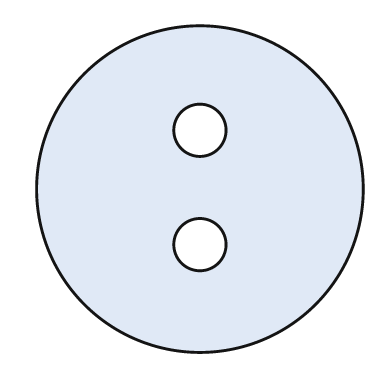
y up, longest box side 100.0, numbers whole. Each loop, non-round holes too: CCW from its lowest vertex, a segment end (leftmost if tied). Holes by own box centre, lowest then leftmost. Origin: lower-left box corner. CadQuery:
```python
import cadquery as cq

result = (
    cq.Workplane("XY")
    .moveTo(50.0, 50.0)
    .circle(50.0)
    .moveTo(50.0, 33.0)
    .circle(8.0)
    .moveTo(50.0, 68.0)
    .circle(8.0)
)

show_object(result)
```